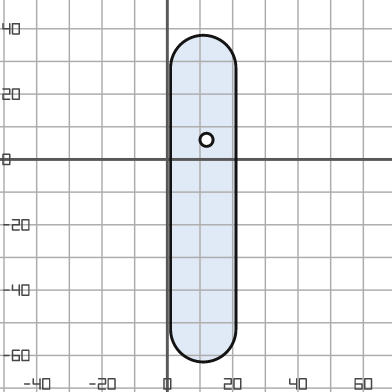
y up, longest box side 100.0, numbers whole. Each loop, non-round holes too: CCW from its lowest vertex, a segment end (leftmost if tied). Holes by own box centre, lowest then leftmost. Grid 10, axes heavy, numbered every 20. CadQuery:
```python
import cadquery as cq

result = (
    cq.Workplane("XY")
    .moveTo(1.0, -52.0)
    .threePointArc((11.0, -62.0), (21.0, -52.0))
    .lineTo(21.0, 28.0)
    .threePointArc((11.0, 38.0), (1.0, 28.0))
    .close()
    .moveTo(12.0, 6.0)
    .circle(2.0)
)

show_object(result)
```